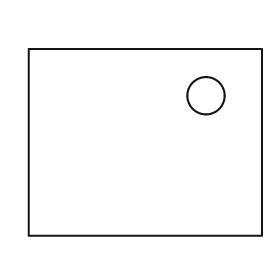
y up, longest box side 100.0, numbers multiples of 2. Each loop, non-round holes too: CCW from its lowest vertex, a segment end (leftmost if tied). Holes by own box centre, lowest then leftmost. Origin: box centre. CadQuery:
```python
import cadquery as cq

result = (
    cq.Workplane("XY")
    .moveTo(-50.0, -40.0)
    .lineTo(50.0, -40.0)
    .lineTo(50.0, 40.0)
    .lineTo(-50.0, 40.0)
    .close()
    .moveTo(26.0, 20.0)
    .circle(8.0)
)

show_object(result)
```